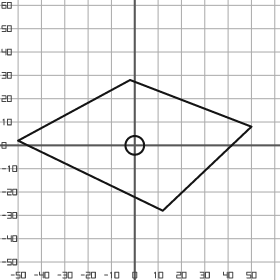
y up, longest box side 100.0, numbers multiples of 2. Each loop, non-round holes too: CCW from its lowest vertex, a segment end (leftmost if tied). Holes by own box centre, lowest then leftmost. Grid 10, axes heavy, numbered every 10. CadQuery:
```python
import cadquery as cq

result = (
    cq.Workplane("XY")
    .moveTo(12.0, -28.0)
    .lineTo(50.0, 8.0)
    .lineTo(-2.0, 28.0)
    .lineTo(-50.0, 2.0)
    .close()
    .moveTo(0.0, 0.0)
    .circle(4.0)
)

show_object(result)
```